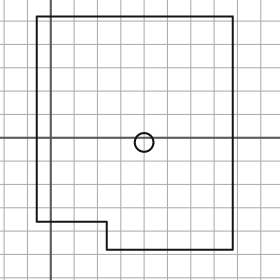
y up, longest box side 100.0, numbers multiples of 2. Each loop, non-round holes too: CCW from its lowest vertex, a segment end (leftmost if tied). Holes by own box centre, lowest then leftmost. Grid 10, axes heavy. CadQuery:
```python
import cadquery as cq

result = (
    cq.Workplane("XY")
    .moveTo(24.0, -48.0)
    .lineTo(78.0, -48.0)
    .lineTo(78.0, 52.0)
    .lineTo(-6.0, 52.0)
    .lineTo(-6.0, -36.0)
    .lineTo(24.0, -36.0)
    .close()
    .moveTo(40.0, -2.0)
    .circle(4.0)
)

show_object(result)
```